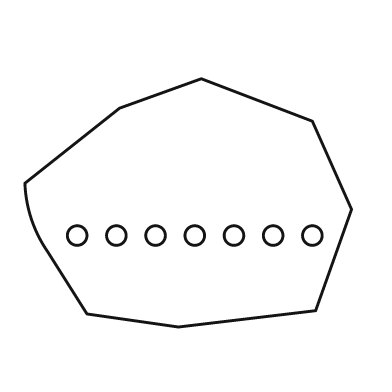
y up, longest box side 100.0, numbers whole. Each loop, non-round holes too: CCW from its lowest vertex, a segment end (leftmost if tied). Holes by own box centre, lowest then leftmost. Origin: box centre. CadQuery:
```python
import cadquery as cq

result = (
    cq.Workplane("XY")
    .moveTo(-3.0, -38.0)
    .lineTo(39.0, -33.0)
    .lineTo(50.0, -2.0)
    .lineTo(38.0, 25.0)
    .lineTo(4.0, 38.0)
    .lineTo(-21.0, 29.0)
    .lineTo(-50.0, 6.0)
    .threePointArc((-48.0, -5.0), (-43.0, -15.0))
    .lineTo(-31.0, -34.0)
    .close()
    .moveTo(-34.0, -10.0)
    .circle(3.0)
    .moveTo(-22.0, -10.0)
    .circle(3.0)
    .moveTo(-10.0, -10.0)
    .circle(3.0)
    .moveTo(2.0, -10.0)
    .circle(3.0)
    .moveTo(14.0, -10.0)
    .circle(3.0)
    .moveTo(26.0, -10.0)
    .circle(3.0)
    .moveTo(38.0, -10.0)
    .circle(3.0)
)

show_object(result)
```